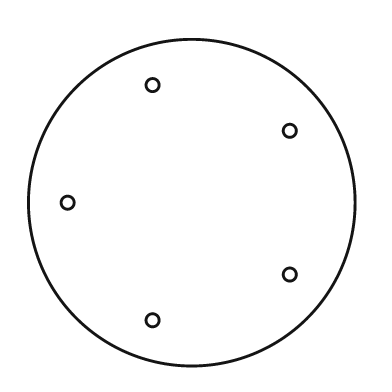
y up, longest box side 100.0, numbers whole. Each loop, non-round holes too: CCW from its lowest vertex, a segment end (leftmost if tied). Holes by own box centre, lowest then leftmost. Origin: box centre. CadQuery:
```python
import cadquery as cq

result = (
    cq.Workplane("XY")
    .moveTo(0.0, 0.0)
    .circle(50.0)
    .moveTo(-12.0, -36.0)
    .circle(2.0)
    .moveTo(30.0, -22.0)
    .circle(2.0)
    .moveTo(-38.0, 0.0)
    .circle(2.0)
    .moveTo(30.0, 22.0)
    .circle(2.0)
    .moveTo(-12.0, 36.0)
    .circle(2.0)
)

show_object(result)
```